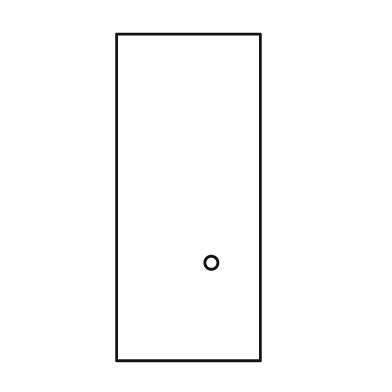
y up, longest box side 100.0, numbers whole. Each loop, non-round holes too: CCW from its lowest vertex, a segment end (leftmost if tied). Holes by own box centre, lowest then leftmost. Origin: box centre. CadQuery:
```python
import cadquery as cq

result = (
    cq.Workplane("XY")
    .moveTo(-22.0, -50.0)
    .lineTo(22.0, -50.0)
    .lineTo(22.0, 50.0)
    .lineTo(-22.0, 50.0)
    .close()
    .moveTo(7.0, -20.0)
    .circle(2.0)
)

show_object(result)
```